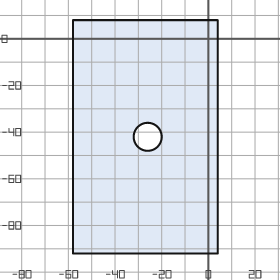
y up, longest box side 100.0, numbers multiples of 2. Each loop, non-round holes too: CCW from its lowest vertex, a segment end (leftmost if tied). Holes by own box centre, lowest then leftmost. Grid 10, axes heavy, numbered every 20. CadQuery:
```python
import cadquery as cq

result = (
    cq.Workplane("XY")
    .moveTo(-58.0, -92.0)
    .lineTo(4.0, -92.0)
    .lineTo(4.0, 8.0)
    .lineTo(-58.0, 8.0)
    .close()
    .moveTo(-26.0, -42.0)
    .circle(6.0)
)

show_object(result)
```